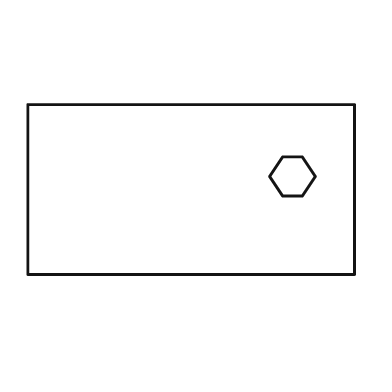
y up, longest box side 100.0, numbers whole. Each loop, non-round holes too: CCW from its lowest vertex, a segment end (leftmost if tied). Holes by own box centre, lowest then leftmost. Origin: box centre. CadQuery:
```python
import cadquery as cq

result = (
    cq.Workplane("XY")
    .moveTo(-50.0, -26.0)
    .lineTo(50.0, -26.0)
    .lineTo(50.0, 26.0)
    .lineTo(-50.0, 26.0)
    .close()
    .moveTo(28.0, -2.0)
    .lineTo(34.0, -2.0)
    .lineTo(38.0, 4.0)
    .lineTo(34.0, 10.0)
    .lineTo(28.0, 10.0)
    .lineTo(24.0, 4.0)
    .close()
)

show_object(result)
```